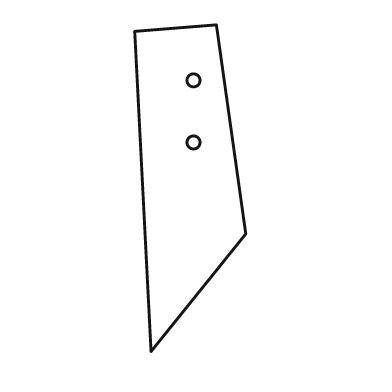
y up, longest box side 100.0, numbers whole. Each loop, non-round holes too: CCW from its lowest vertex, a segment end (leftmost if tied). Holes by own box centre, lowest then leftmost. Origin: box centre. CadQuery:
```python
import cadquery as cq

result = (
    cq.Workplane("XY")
    .moveTo(-12.0, -50.0)
    .lineTo(17.0, -14.0)
    .lineTo(8.0, 50.0)
    .lineTo(-17.0, 48.0)
    .close()
    .moveTo(1.0, 14.0)
    .circle(2.0)
    .moveTo(1.0, 33.0)
    .circle(2.0)
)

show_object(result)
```